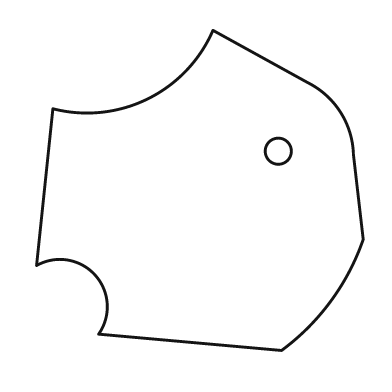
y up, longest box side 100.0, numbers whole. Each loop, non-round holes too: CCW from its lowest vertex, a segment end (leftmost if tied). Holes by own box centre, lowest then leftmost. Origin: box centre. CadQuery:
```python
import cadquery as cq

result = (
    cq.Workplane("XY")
    .moveTo(25.0, -49.0)
    .threePointArc((40.0, -34.0), (50.0, -15.0))
    .lineTo(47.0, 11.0)
    .threePointArc((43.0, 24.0), (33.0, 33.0))
    .lineTo(4.0, 49.0)
    .threePointArc((-16.0, 28.0), (-45.0, 25.0))
    .lineTo(-50.0, -23.0)
    .threePointArc((-32.0, -26.0), (-31.0, -44.0))
    .close()
    .moveTo(24.0, 12.0)
    .circle(4.0)
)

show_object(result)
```